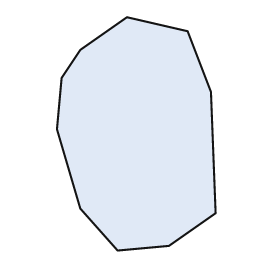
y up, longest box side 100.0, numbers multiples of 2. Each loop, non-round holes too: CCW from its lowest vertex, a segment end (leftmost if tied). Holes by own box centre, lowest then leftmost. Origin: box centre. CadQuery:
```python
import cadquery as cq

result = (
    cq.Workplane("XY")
    .moveTo(-8.0, -50.0)
    .lineTo(14.0, -48.0)
    .lineTo(34.0, -34.0)
    .lineTo(32.0, 18.0)
    .lineTo(22.0, 44.0)
    .lineTo(-4.0, 50.0)
    .lineTo(-24.0, 36.0)
    .lineTo(-32.0, 24.0)
    .lineTo(-34.0, 2.0)
    .lineTo(-24.0, -32.0)
    .close()
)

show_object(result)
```